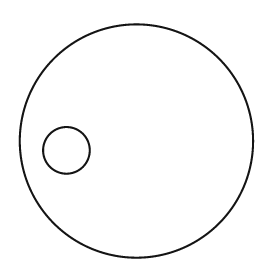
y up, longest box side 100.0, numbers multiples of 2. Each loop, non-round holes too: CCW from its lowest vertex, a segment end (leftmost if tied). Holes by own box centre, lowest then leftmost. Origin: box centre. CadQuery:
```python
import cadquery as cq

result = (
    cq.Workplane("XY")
    .moveTo(0.0, 0.0)
    .circle(50.0)
    .moveTo(-30.0, -4.0)
    .circle(10.0)
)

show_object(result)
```